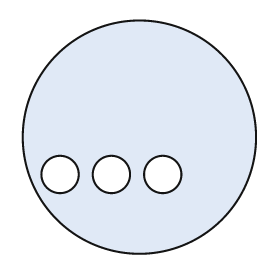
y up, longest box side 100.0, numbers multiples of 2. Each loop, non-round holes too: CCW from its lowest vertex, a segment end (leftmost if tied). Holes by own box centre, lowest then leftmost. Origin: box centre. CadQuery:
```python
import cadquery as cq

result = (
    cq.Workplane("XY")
    .moveTo(0.0, 0.0)
    .circle(50.0)
    .moveTo(-34.0, -16.0)
    .circle(8.0)
    .moveTo(-12.0, -16.0)
    .circle(8.0)
    .moveTo(10.0, -16.0)
    .circle(8.0)
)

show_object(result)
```